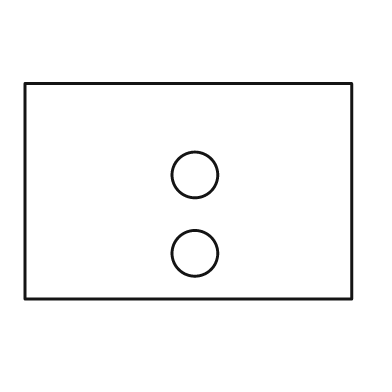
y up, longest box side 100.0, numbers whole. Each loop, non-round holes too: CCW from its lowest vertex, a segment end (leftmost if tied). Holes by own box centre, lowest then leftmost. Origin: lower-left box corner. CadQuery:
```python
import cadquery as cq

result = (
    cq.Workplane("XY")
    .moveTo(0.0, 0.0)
    .lineTo(100.0, 0.0)
    .lineTo(100.0, 66.0)
    .lineTo(0.0, 66.0)
    .close()
    .moveTo(52.0, 14.0)
    .circle(7.0)
    .moveTo(52.0, 38.0)
    .circle(7.0)
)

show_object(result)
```